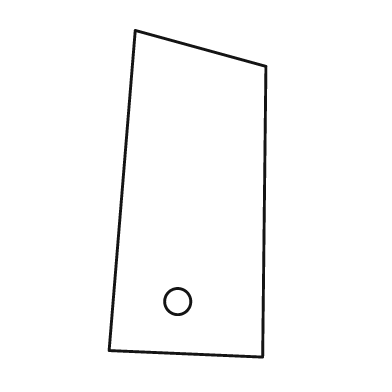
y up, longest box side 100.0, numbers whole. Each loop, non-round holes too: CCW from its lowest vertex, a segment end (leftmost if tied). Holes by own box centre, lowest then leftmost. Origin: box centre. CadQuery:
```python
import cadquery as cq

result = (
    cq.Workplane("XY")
    .moveTo(23.0, -50.0)
    .lineTo(24.0, 39.0)
    .lineTo(-16.0, 50.0)
    .lineTo(-24.0, -48.0)
    .close()
    .moveTo(-3.0, -33.0)
    .circle(4.0)
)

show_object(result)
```